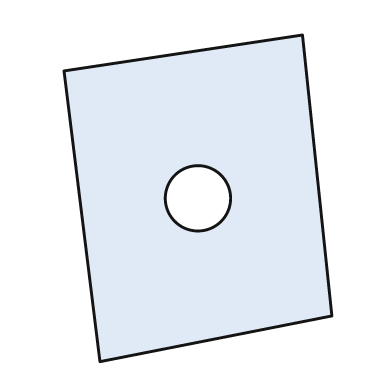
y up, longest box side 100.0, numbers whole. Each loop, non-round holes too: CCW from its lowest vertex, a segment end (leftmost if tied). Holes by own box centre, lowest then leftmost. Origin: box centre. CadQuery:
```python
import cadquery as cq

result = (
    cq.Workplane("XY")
    .moveTo(-30.0, -50.0)
    .lineTo(41.0, -36.0)
    .lineTo(32.0, 50.0)
    .lineTo(-41.0, 39.0)
    .close()
    .moveTo(0.0, 0.0)
    .circle(10.0)
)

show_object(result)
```